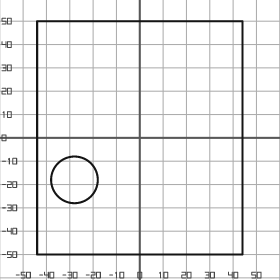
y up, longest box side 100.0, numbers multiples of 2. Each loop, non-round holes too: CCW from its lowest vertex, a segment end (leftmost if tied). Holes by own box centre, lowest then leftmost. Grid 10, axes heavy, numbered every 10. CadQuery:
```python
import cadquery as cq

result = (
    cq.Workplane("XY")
    .moveTo(-44.0, -50.0)
    .lineTo(44.0, -50.0)
    .lineTo(44.0, 50.0)
    .lineTo(-44.0, 50.0)
    .close()
    .moveTo(-28.0, -18.0)
    .circle(10.0)
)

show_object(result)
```